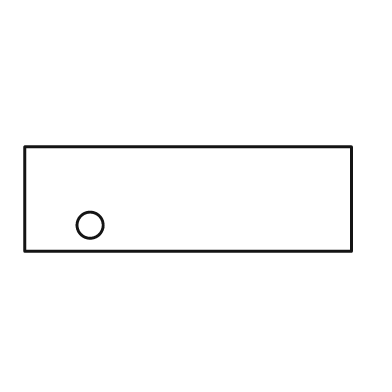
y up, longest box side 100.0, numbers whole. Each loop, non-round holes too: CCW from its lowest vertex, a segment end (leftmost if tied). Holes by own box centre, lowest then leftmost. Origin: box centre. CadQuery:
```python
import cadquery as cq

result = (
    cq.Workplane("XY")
    .moveTo(-50.0, -16.0)
    .lineTo(50.0, -16.0)
    .lineTo(50.0, 16.0)
    .lineTo(-50.0, 16.0)
    .close()
    .moveTo(-30.0, -8.0)
    .circle(4.0)
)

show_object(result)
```